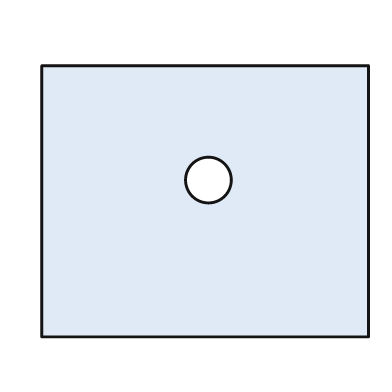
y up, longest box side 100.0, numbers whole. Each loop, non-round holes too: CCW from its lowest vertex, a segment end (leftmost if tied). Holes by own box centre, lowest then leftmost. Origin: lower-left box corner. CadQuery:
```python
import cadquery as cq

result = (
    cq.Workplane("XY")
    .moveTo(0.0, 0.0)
    .lineTo(100.0, 0.0)
    .lineTo(100.0, 83.0)
    .lineTo(0.0, 83.0)
    .close()
    .moveTo(51.0, 48.0)
    .circle(7.0)
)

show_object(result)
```